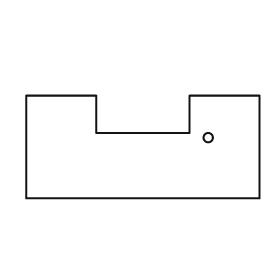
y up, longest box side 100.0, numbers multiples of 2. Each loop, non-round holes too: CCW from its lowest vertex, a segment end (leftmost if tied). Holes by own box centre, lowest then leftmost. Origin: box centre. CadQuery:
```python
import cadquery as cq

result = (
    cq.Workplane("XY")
    .moveTo(-50.0, -22.0)
    .lineTo(50.0, -22.0)
    .lineTo(50.0, 22.0)
    .lineTo(20.0, 22.0)
    .lineTo(20.0, 6.0)
    .lineTo(-20.0, 6.0)
    .lineTo(-20.0, 22.0)
    .lineTo(-50.0, 22.0)
    .close()
    .moveTo(28.0, 4.0)
    .circle(2.0)
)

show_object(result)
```